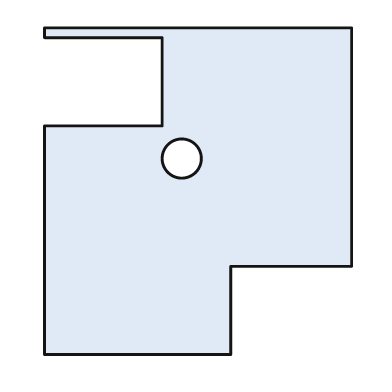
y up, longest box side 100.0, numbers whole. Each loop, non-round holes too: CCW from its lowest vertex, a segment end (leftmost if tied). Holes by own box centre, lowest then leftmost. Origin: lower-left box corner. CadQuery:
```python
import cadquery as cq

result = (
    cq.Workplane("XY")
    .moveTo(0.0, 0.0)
    .lineTo(57.0, 0.0)
    .lineTo(57.0, 27.0)
    .lineTo(94.0, 27.0)
    .lineTo(94.0, 100.0)
    .lineTo(0.0, 100.0)
    .lineTo(0.0, 97.0)
    .lineTo(36.0, 97.0)
    .lineTo(36.0, 70.0)
    .lineTo(0.0, 70.0)
    .close()
    .moveTo(42.0, 60.0)
    .circle(6.0)
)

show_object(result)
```